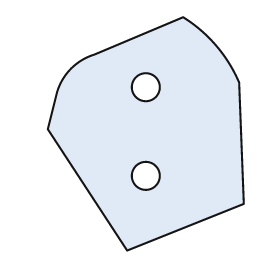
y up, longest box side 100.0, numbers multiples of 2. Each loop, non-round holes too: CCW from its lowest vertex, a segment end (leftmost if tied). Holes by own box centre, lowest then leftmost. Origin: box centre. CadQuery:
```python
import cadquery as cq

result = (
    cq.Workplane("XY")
    .moveTo(-8.0, -50.0)
    .lineTo(42.0, -30.0)
    .lineTo(40.0, 22.0)
    .threePointArc((30.0, 38.0), (16.0, 50.0))
    .lineTo(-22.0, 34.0)
    .threePointArc((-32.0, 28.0), (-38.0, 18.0))
    .lineTo(-42.0, 2.0)
    .close()
    .moveTo(0.0, -18.0)
    .circle(6.0)
    .moveTo(0.0, 20.0)
    .circle(6.0)
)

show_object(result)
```